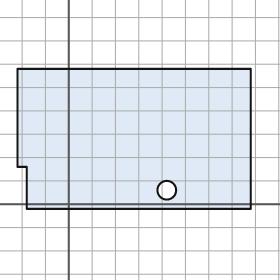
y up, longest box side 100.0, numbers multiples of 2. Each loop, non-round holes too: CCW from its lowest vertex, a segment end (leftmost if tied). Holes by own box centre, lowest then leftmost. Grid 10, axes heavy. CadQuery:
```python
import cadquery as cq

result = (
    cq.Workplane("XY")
    .moveTo(-18.0, -2.0)
    .lineTo(78.0, -2.0)
    .lineTo(78.0, 58.0)
    .lineTo(-22.0, 58.0)
    .lineTo(-22.0, 16.0)
    .lineTo(-18.0, 16.0)
    .close()
    .moveTo(42.0, 6.0)
    .circle(4.0)
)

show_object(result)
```